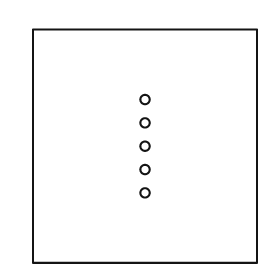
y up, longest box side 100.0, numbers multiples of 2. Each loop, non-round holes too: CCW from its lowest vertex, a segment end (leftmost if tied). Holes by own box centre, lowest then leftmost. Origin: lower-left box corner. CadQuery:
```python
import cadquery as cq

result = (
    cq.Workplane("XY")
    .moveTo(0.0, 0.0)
    .lineTo(96.0, 0.0)
    .lineTo(96.0, 100.0)
    .lineTo(0.0, 100.0)
    .close()
    .moveTo(48.0, 30.0)
    .circle(2.0)
    .moveTo(48.0, 40.0)
    .circle(2.0)
    .moveTo(48.0, 50.0)
    .circle(2.0)
    .moveTo(48.0, 60.0)
    .circle(2.0)
    .moveTo(48.0, 70.0)
    .circle(2.0)
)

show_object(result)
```